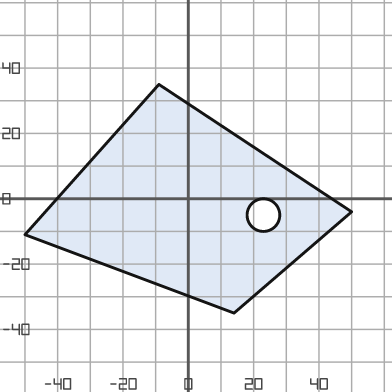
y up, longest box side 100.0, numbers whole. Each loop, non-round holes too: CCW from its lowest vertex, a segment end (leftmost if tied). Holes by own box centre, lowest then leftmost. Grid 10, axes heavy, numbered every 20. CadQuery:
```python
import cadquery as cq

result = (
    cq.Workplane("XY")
    .moveTo(14.0, -35.0)
    .lineTo(50.0, -4.0)
    .lineTo(-9.0, 35.0)
    .lineTo(-50.0, -11.0)
    .close()
    .moveTo(23.0, -5.0)
    .circle(5.0)
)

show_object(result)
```